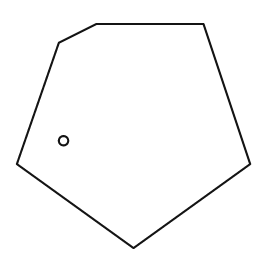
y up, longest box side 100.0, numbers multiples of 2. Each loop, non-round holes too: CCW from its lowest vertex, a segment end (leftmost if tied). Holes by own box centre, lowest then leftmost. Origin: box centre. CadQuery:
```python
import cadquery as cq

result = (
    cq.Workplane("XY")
    .moveTo(0.0, -48.0)
    .lineTo(50.0, -12.0)
    .lineTo(30.0, 48.0)
    .lineTo(-16.0, 48.0)
    .lineTo(-32.0, 40.0)
    .lineTo(-50.0, -12.0)
    .close()
    .moveTo(-30.0, -2.0)
    .circle(2.0)
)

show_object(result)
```